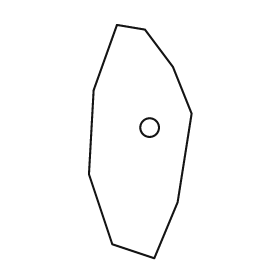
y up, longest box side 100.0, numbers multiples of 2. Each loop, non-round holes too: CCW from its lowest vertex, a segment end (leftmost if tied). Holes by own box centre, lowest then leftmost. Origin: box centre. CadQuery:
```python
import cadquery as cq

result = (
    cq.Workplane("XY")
    .moveTo(6.0, -50.0)
    .lineTo(16.0, -26.0)
    .lineTo(22.0, 12.0)
    .lineTo(14.0, 32.0)
    .lineTo(2.0, 48.0)
    .lineTo(-10.0, 50.0)
    .lineTo(-20.0, 22.0)
    .lineTo(-22.0, -14.0)
    .lineTo(-12.0, -44.0)
    .close()
    .moveTo(4.0, 6.0)
    .circle(4.0)
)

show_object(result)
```